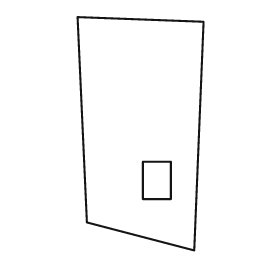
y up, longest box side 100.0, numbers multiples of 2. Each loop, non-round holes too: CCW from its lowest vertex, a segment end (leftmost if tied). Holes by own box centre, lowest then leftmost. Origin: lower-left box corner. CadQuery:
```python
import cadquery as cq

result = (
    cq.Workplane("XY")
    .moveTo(50.0, 0.0)
    .lineTo(54.0, 98.0)
    .lineTo(0.0, 100.0)
    .lineTo(4.0, 12.0)
    .close()
    .moveTo(28.0, 22.0)
    .lineTo(40.0, 22.0)
    .lineTo(40.0, 38.0)
    .lineTo(28.0, 38.0)
    .close()
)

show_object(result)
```